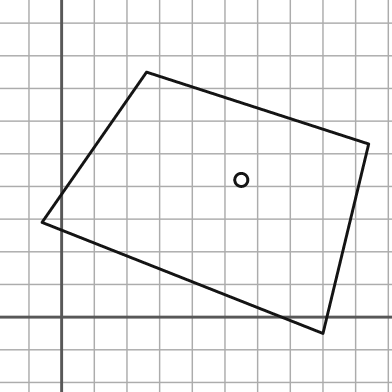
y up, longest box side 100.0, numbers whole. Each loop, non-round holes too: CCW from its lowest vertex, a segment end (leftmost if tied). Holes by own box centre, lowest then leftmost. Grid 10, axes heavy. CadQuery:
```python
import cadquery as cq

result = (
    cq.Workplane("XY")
    .moveTo(80.0, -5.0)
    .lineTo(94.0, 53.0)
    .lineTo(26.0, 75.0)
    .lineTo(-6.0, 29.0)
    .close()
    .moveTo(55.0, 42.0)
    .circle(2.0)
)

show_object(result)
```